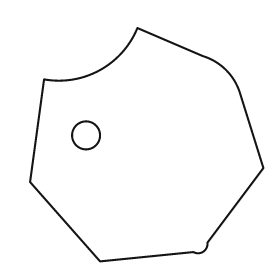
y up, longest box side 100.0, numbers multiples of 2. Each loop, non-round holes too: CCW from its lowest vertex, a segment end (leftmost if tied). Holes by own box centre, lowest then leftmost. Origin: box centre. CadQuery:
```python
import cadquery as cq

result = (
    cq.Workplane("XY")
    .moveTo(-20.0, -50.0)
    .lineTo(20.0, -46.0)
    .threePointArc((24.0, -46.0), (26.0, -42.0))
    .lineTo(50.0, -10.0)
    .lineTo(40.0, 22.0)
    .threePointArc((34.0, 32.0), (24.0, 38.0))
    .lineTo(-4.0, 50.0)
    .threePointArc((-20.0, 32.0), (-44.0, 28.0))
    .lineTo(-50.0, -16.0)
    .close()
    .moveTo(-26.0, 4.0)
    .circle(6.0)
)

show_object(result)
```